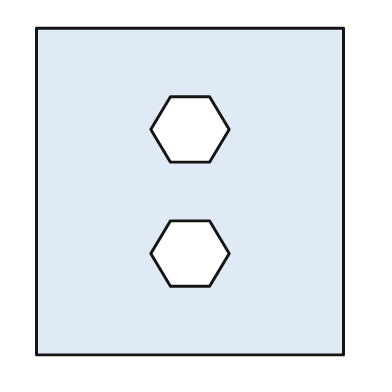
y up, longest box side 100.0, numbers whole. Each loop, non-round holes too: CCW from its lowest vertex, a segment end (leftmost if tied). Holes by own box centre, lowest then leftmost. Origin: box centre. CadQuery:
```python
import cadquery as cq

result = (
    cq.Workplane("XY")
    .moveTo(-47.0, -50.0)
    .lineTo(47.0, -50.0)
    .lineTo(47.0, 50.0)
    .lineTo(-47.0, 50.0)
    .close()
    .moveTo(-6.0, -29.0)
    .lineTo(6.0, -29.0)
    .lineTo(12.0, -19.0)
    .lineTo(6.0, -9.0)
    .lineTo(-6.0, -9.0)
    .lineTo(-12.0, -19.0)
    .close()
    .moveTo(-6.0, 9.0)
    .lineTo(6.0, 9.0)
    .lineTo(12.0, 19.0)
    .lineTo(6.0, 29.0)
    .lineTo(-6.0, 29.0)
    .lineTo(-12.0, 19.0)
    .close()
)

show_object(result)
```